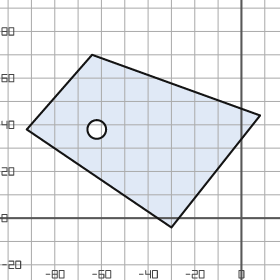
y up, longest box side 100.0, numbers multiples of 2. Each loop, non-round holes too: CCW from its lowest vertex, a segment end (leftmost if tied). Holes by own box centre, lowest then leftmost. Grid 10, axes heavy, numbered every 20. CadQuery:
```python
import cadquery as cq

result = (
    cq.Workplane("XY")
    .moveTo(-30.0, -4.0)
    .lineTo(8.0, 44.0)
    .lineTo(-64.0, 70.0)
    .lineTo(-92.0, 38.0)
    .close()
    .moveTo(-62.0, 38.0)
    .circle(4.0)
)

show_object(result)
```